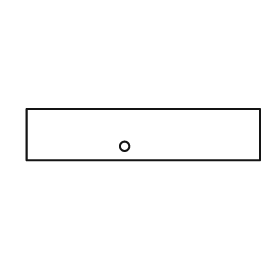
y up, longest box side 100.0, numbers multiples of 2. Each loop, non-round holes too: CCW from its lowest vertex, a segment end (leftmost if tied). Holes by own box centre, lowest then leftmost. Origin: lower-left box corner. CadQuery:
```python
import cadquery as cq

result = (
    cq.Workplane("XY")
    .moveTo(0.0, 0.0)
    .lineTo(100.0, 0.0)
    .lineTo(100.0, 22.0)
    .lineTo(0.0, 22.0)
    .close()
    .moveTo(42.0, 6.0)
    .circle(2.0)
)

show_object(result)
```